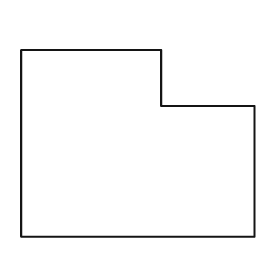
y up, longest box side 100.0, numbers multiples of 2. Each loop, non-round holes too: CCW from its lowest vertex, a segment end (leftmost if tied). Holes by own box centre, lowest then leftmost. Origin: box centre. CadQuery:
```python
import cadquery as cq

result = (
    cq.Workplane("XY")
    .moveTo(-50.0, -40.0)
    .lineTo(50.0, -40.0)
    .lineTo(50.0, 16.0)
    .lineTo(10.0, 16.0)
    .lineTo(10.0, 40.0)
    .lineTo(-50.0, 40.0)
    .close()
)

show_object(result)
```